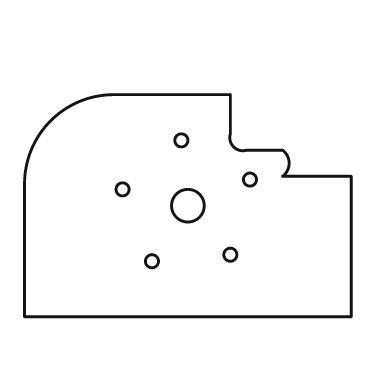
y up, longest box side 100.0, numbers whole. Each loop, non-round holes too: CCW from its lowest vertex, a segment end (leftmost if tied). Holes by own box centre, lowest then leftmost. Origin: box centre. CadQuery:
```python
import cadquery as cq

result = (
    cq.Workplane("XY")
    .moveTo(-50.0, -34.0)
    .lineTo(50.0, -34.0)
    .lineTo(50.0, 9.0)
    .lineTo(29.0, 9.0)
    .threePointArc((31.0, 13.0), (29.0, 17.0))
    .lineTo(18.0, 17.0)
    .threePointArc((14.0, 18.0), (13.0, 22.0))
    .lineTo(13.0, 34.0)
    .lineTo(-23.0, 34.0)
    .threePointArc((-42.0, 26.0), (-50.0, 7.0))
    .close()
    .moveTo(-11.0, -17.0)
    .circle(2.0)
    .moveTo(13.0, -15.0)
    .circle(2.0)
    .moveTo(0.0, 0.0)
    .circle(5.0)
    .moveTo(-20.0, 5.0)
    .circle(2.0)
    .moveTo(19.0, 8.0)
    .circle(2.0)
    .moveTo(-2.0, 20.0)
    .circle(2.0)
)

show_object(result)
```